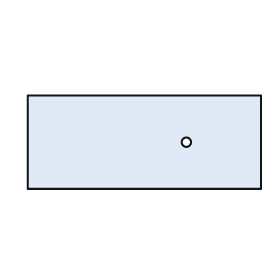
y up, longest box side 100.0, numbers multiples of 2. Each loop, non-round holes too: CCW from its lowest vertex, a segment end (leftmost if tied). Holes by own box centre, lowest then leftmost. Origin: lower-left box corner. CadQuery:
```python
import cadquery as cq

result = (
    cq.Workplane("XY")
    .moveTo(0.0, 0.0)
    .lineTo(100.0, 0.0)
    .lineTo(100.0, 40.0)
    .lineTo(0.0, 40.0)
    .close()
    .moveTo(68.0, 20.0)
    .circle(2.0)
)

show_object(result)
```